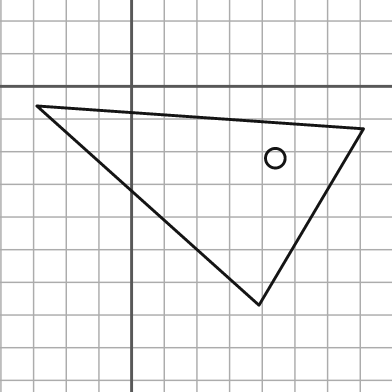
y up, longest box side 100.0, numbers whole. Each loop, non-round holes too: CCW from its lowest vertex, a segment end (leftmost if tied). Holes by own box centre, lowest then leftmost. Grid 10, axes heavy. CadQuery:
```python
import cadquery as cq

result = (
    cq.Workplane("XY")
    .moveTo(39.0, -67.0)
    .lineTo(71.0, -13.0)
    .lineTo(-29.0, -6.0)
    .close()
    .moveTo(44.0, -22.0)
    .circle(3.0)
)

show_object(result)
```